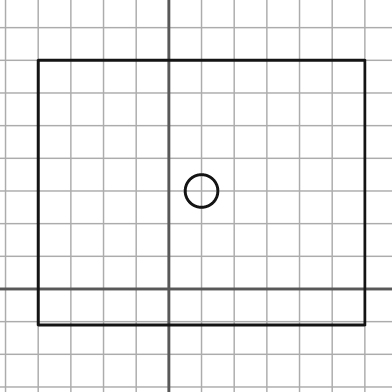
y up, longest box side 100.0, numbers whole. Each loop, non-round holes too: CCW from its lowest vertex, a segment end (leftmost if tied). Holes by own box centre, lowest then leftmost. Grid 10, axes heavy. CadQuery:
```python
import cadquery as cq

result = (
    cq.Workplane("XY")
    .moveTo(-40.0, -11.0)
    .lineTo(60.0, -11.0)
    .lineTo(60.0, 70.0)
    .lineTo(-40.0, 70.0)
    .close()
    .moveTo(10.0, 30.0)
    .circle(5.0)
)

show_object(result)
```